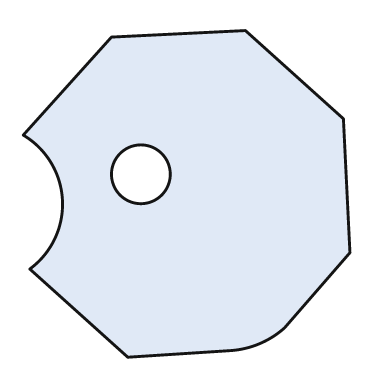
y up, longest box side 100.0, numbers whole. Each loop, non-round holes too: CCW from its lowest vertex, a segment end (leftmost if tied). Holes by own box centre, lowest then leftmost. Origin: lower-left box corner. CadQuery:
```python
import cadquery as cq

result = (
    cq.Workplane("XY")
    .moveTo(32.0, 0.0)
    .lineTo(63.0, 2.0)
    .threePointArc((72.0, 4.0), (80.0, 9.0))
    .lineTo(100.0, 32.0)
    .lineTo(98.0, 73.0)
    .lineTo(68.0, 100.0)
    .lineTo(27.0, 98.0)
    .lineTo(0.0, 68.0)
    .threePointArc((12.0, 48.0), (2.0, 27.0))
    .close()
    .moveTo(36.0, 56.0)
    .circle(9.0)
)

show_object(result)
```